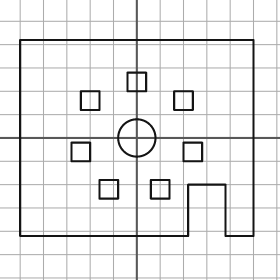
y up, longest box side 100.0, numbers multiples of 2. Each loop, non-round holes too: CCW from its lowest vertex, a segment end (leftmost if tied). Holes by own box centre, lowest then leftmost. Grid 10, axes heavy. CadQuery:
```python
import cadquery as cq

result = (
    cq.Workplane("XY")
    .moveTo(-50.0, -42.0)
    .lineTo(22.0, -42.0)
    .lineTo(22.0, -20.0)
    .lineTo(38.0, -20.0)
    .lineTo(38.0, -42.0)
    .lineTo(50.0, -42.0)
    .lineTo(50.0, 42.0)
    .lineTo(-50.0, 42.0)
    .close()
    .moveTo(-16.0, -26.0)
    .lineTo(-8.0, -26.0)
    .lineTo(-8.0, -18.0)
    .lineTo(-16.0, -18.0)
    .close()
    .moveTo(6.0, -26.0)
    .lineTo(14.0, -26.0)
    .lineTo(14.0, -18.0)
    .lineTo(6.0, -18.0)
    .close()
    .moveTo(-28.0, -10.0)
    .lineTo(-20.0, -10.0)
    .lineTo(-20.0, -2.0)
    .lineTo(-28.0, -2.0)
    .close()
    .moveTo(20.0, -10.0)
    .lineTo(28.0, -10.0)
    .lineTo(28.0, -2.0)
    .lineTo(20.0, -2.0)
    .close()
    .moveTo(0.0, 0.0)
    .circle(8.0)
    .moveTo(-24.0, 12.0)
    .lineTo(-16.0, 12.0)
    .lineTo(-16.0, 20.0)
    .lineTo(-24.0, 20.0)
    .close()
    .moveTo(16.0, 12.0)
    .lineTo(24.0, 12.0)
    .lineTo(24.0, 20.0)
    .lineTo(16.0, 20.0)
    .close()
    .moveTo(-4.0, 20.0)
    .lineTo(4.0, 20.0)
    .lineTo(4.0, 28.0)
    .lineTo(-4.0, 28.0)
    .close()
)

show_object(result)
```